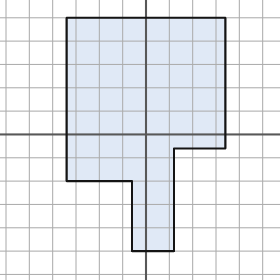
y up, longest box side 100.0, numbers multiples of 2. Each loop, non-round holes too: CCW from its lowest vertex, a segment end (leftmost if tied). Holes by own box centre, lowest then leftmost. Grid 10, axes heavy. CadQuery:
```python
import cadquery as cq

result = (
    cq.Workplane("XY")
    .moveTo(-6.0, -50.0)
    .lineTo(12.0, -50.0)
    .lineTo(12.0, -6.0)
    .lineTo(34.0, -6.0)
    .lineTo(34.0, 50.0)
    .lineTo(-34.0, 50.0)
    .lineTo(-34.0, -20.0)
    .lineTo(-6.0, -20.0)
    .close()
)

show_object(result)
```